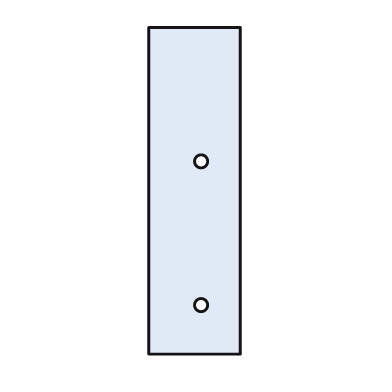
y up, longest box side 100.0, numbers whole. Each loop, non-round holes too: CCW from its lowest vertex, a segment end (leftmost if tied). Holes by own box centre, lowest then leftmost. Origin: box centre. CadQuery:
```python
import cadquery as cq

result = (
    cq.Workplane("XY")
    .moveTo(-14.0, -50.0)
    .lineTo(14.0, -50.0)
    .lineTo(14.0, 50.0)
    .lineTo(-14.0, 50.0)
    .close()
    .moveTo(2.0, -35.0)
    .circle(2.0)
    .moveTo(2.0, 9.0)
    .circle(2.0)
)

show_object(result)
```